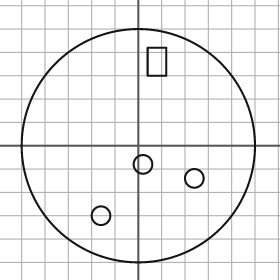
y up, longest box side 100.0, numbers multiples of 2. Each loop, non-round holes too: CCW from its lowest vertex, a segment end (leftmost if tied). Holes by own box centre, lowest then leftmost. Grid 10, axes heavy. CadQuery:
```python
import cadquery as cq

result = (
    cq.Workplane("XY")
    .moveTo(0.0, 0.0)
    .circle(50.0)
    .moveTo(-16.0, -30.0)
    .circle(4.0)
    .moveTo(24.0, -14.0)
    .circle(4.0)
    .moveTo(2.0, -8.0)
    .circle(4.0)
    .moveTo(4.0, 30.0)
    .lineTo(12.0, 30.0)
    .lineTo(12.0, 42.0)
    .lineTo(4.0, 42.0)
    .close()
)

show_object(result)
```